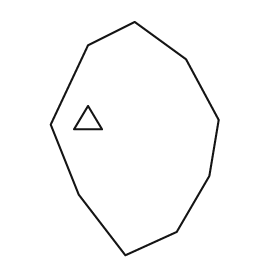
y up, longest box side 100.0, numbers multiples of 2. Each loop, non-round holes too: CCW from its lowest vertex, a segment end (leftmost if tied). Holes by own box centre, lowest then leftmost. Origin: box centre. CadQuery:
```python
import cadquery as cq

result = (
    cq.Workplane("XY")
    .moveTo(-4.0, -50.0)
    .lineTo(18.0, -40.0)
    .lineTo(32.0, -16.0)
    .lineTo(36.0, 8.0)
    .lineTo(22.0, 34.0)
    .lineTo(0.0, 50.0)
    .lineTo(-20.0, 40.0)
    .lineTo(-36.0, 6.0)
    .lineTo(-24.0, -24.0)
    .close()
    .moveTo(-26.0, 4.0)
    .lineTo(-14.0, 4.0)
    .lineTo(-20.0, 14.0)
    .close()
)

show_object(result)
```